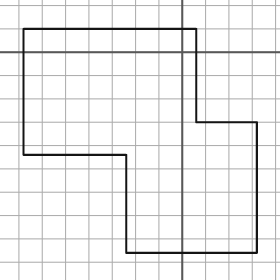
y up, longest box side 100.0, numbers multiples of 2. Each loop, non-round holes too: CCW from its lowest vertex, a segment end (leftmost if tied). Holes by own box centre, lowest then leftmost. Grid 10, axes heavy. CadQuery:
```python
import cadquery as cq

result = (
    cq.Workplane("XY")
    .moveTo(-24.0, -86.0)
    .lineTo(32.0, -86.0)
    .lineTo(32.0, -30.0)
    .lineTo(6.0, -30.0)
    .lineTo(6.0, 10.0)
    .lineTo(-68.0, 10.0)
    .lineTo(-68.0, -44.0)
    .lineTo(-24.0, -44.0)
    .close()
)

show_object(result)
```